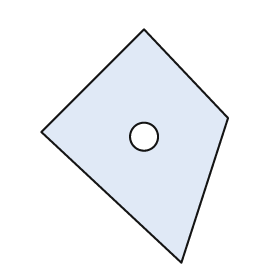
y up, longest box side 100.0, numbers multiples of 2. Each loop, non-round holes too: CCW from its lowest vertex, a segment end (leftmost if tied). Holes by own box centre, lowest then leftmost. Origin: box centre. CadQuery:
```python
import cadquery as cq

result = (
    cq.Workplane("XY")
    .moveTo(20.0, -50.0)
    .lineTo(40.0, 12.0)
    .lineTo(4.0, 50.0)
    .lineTo(-40.0, 6.0)
    .close()
    .moveTo(4.0, 4.0)
    .circle(6.0)
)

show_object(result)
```